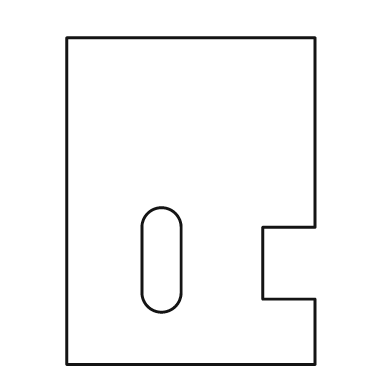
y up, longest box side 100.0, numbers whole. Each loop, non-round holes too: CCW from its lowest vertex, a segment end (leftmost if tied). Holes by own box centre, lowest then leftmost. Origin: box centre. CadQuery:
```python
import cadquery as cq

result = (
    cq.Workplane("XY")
    .moveTo(-38.0, -50.0)
    .lineTo(38.0, -50.0)
    .lineTo(38.0, -30.0)
    .lineTo(22.0, -30.0)
    .lineTo(22.0, -8.0)
    .lineTo(38.0, -8.0)
    .lineTo(38.0, 50.0)
    .lineTo(-38.0, 50.0)
    .close()
    .moveTo(-15.0, -28.0)
    .threePointArc((-9.0, -34.0), (-3.0, -28.0))
    .lineTo(-3.0, -8.0)
    .threePointArc((-9.0, -2.0), (-15.0, -8.0))
    .close()
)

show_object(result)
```